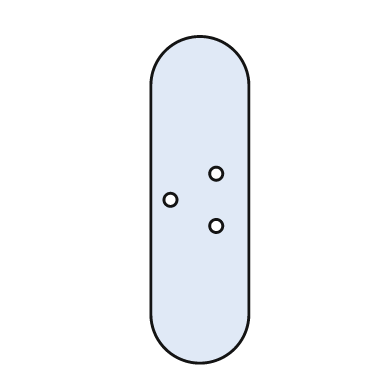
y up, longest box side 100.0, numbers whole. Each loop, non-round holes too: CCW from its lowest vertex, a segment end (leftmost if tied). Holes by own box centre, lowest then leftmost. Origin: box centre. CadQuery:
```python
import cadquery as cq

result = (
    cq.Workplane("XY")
    .moveTo(-15.0, -35.0)
    .threePointArc((0.0, -50.0), (15.0, -35.0))
    .lineTo(15.0, 35.0)
    .threePointArc((0.0, 50.0), (-15.0, 35.0))
    .close()
    .moveTo(5.0, -8.0)
    .circle(2.0)
    .moveTo(-9.0, 0.0)
    .circle(2.0)
    .moveTo(5.0, 8.0)
    .circle(2.0)
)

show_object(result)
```